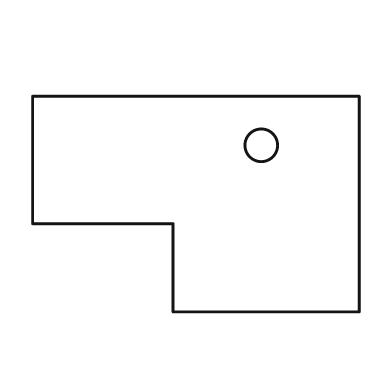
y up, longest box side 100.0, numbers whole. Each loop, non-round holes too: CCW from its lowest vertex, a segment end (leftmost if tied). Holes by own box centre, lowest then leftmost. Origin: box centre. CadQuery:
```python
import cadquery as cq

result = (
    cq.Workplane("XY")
    .moveTo(-7.0, -33.0)
    .lineTo(50.0, -33.0)
    .lineTo(50.0, 33.0)
    .lineTo(-50.0, 33.0)
    .lineTo(-50.0, -6.0)
    .lineTo(-7.0, -6.0)
    .close()
    .moveTo(20.0, 18.0)
    .circle(5.0)
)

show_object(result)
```